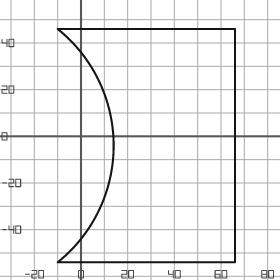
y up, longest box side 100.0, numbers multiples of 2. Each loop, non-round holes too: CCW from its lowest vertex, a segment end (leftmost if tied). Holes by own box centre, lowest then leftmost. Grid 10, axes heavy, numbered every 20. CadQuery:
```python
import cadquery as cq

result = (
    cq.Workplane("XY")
    .moveTo(-10.0, -54.0)
    .lineTo(66.0, -54.0)
    .lineTo(66.0, 46.0)
    .lineTo(-10.0, 46.0)
    .threePointArc((14.0, -4.0), (-10.0, -54.0))
    .close()
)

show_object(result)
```